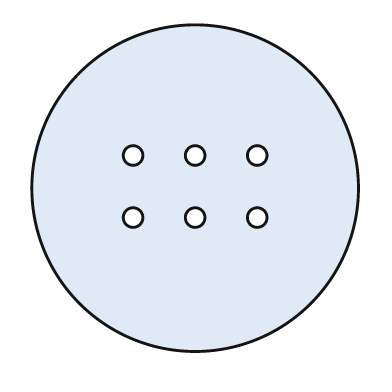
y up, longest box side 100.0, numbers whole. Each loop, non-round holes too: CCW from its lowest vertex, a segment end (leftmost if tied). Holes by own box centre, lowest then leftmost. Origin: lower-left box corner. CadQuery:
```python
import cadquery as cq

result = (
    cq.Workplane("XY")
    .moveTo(50.0, 50.0)
    .circle(50.0)
    .moveTo(31.0, 41.0)
    .circle(3.0)
    .moveTo(50.0, 41.0)
    .circle(3.0)
    .moveTo(69.0, 41.0)
    .circle(3.0)
    .moveTo(31.0, 60.0)
    .circle(3.0)
    .moveTo(50.0, 60.0)
    .circle(3.0)
    .moveTo(69.0, 60.0)
    .circle(3.0)
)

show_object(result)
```